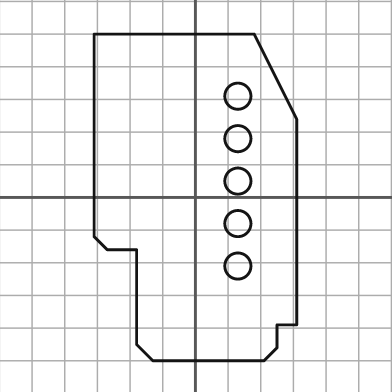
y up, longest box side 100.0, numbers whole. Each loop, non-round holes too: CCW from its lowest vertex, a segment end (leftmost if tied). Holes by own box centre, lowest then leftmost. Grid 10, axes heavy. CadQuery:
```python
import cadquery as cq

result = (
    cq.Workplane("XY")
    .moveTo(-13.0, -50.0)
    .lineTo(21.0, -50.0)
    .lineTo(25.0, -46.0)
    .lineTo(25.0, -39.0)
    .lineTo(31.0, -39.0)
    .lineTo(31.0, 24.0)
    .lineTo(18.0, 50.0)
    .lineTo(-31.0, 50.0)
    .lineTo(-31.0, -12.0)
    .lineTo(-27.0, -16.0)
    .lineTo(-18.0, -16.0)
    .lineTo(-18.0, -45.0)
    .close()
    .moveTo(13.0, -21.0)
    .circle(4.0)
    .moveTo(13.0, -8.0)
    .circle(4.0)
    .moveTo(13.0, 5.0)
    .circle(4.0)
    .moveTo(13.0, 18.0)
    .circle(4.0)
    .moveTo(13.0, 31.0)
    .circle(4.0)
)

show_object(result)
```